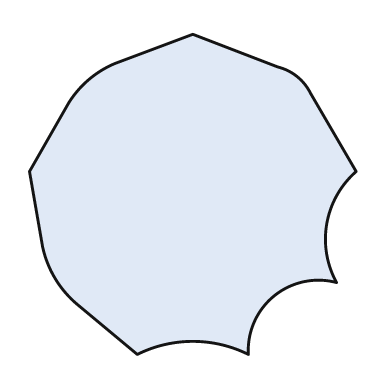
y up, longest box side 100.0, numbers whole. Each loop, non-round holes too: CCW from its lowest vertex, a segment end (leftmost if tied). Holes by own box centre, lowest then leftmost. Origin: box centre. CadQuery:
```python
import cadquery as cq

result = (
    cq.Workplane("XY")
    .moveTo(-17.0, -49.0)
    .threePointArc((0.0, -45.0), (17.0, -49.0))
    .threePointArc((25.0, -31.0), (44.0, -27.0))
    .threePointArc((41.0, -9.0), (50.0, 7.0))
    .lineTo(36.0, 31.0)
    .threePointArc((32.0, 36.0), (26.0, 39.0))
    .lineTo(0.0, 49.0)
    .lineTo(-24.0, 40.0)
    .threePointArc((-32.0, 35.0), (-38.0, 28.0))
    .lineTo(-50.0, 7.0)
    .lineTo(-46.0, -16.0)
    .threePointArc((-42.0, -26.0), (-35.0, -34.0))
    .close()
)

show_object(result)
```